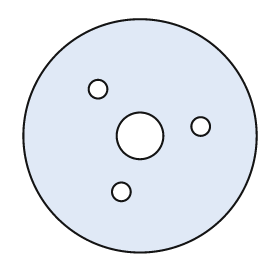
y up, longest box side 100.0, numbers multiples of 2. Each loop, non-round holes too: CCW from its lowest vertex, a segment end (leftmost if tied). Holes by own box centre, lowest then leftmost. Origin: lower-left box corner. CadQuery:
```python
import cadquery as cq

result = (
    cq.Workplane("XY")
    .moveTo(50.0, 50.0)
    .circle(50.0)
    .moveTo(42.0, 26.0)
    .circle(4.0)
    .moveTo(50.0, 50.0)
    .circle(10.0)
    .moveTo(76.0, 54.0)
    .circle(4.0)
    .moveTo(32.0, 70.0)
    .circle(4.0)
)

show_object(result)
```